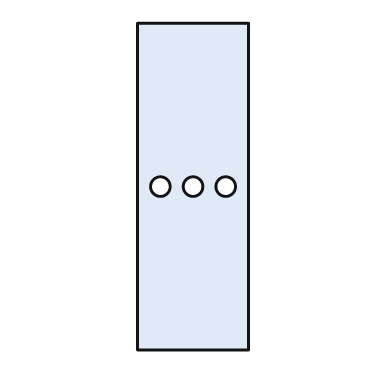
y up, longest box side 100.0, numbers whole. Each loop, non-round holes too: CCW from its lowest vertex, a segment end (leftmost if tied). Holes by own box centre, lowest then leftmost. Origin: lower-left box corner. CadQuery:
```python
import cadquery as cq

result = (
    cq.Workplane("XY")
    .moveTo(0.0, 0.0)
    .lineTo(34.0, 0.0)
    .lineTo(34.0, 100.0)
    .lineTo(0.0, 100.0)
    .close()
    .moveTo(7.0, 50.0)
    .circle(3.0)
    .moveTo(17.0, 50.0)
    .circle(3.0)
    .moveTo(27.0, 50.0)
    .circle(3.0)
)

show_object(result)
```